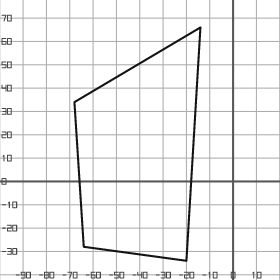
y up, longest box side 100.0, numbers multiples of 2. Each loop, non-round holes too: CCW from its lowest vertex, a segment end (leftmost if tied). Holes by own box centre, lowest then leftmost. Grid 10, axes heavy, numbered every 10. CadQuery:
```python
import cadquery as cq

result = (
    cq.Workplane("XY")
    .moveTo(-20.0, -34.0)
    .lineTo(-14.0, 66.0)
    .lineTo(-68.0, 34.0)
    .lineTo(-64.0, -28.0)
    .close()
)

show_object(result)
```